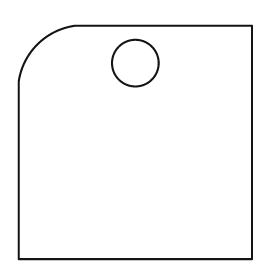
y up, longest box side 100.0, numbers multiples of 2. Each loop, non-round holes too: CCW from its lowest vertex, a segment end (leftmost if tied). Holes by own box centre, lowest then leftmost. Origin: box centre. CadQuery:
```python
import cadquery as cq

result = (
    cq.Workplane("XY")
    .moveTo(-50.0, -50.0)
    .lineTo(50.0, -50.0)
    .lineTo(50.0, 50.0)
    .lineTo(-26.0, 50.0)
    .threePointArc((-42.0, 42.0), (-50.0, 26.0))
    .close()
    .moveTo(0.0, 34.0)
    .circle(10.0)
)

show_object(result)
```